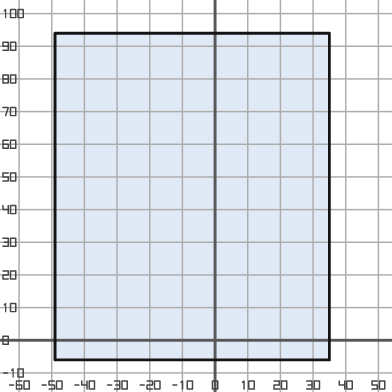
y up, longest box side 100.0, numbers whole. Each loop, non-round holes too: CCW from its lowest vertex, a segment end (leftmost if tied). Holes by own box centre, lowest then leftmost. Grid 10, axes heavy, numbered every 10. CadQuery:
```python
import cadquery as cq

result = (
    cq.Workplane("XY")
    .moveTo(-49.0, -6.0)
    .lineTo(35.0, -6.0)
    .lineTo(35.0, 94.0)
    .lineTo(-49.0, 94.0)
    .close()
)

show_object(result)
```